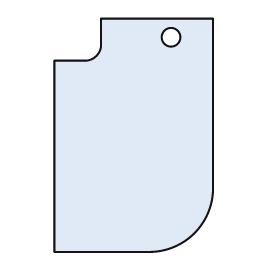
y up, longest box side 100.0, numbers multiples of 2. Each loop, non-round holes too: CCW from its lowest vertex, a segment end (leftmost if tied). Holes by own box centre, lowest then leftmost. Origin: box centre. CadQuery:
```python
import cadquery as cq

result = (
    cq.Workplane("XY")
    .moveTo(-34.0, -50.0)
    .lineTo(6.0, -50.0)
    .threePointArc((26.0, -42.0), (34.0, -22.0))
    .lineTo(34.0, 50.0)
    .lineTo(-14.0, 50.0)
    .lineTo(-14.0, 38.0)
    .threePointArc((-16.0, 34.0), (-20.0, 32.0))
    .lineTo(-34.0, 32.0)
    .close()
    .moveTo(16.0, 42.0)
    .circle(4.0)
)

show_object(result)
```